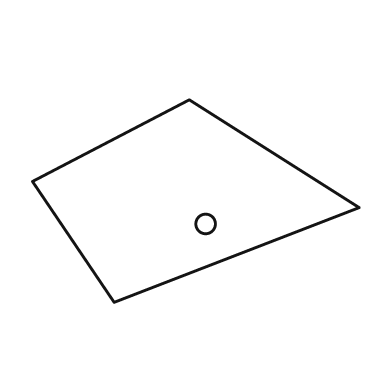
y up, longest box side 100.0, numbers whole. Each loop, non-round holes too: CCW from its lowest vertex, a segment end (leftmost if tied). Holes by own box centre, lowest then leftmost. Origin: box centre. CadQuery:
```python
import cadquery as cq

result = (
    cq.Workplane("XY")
    .moveTo(-25.0, -31.0)
    .lineTo(50.0, -2.0)
    .lineTo(-2.0, 31.0)
    .lineTo(-50.0, 6.0)
    .close()
    .moveTo(3.0, -7.0)
    .circle(3.0)
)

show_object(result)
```